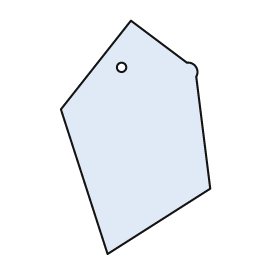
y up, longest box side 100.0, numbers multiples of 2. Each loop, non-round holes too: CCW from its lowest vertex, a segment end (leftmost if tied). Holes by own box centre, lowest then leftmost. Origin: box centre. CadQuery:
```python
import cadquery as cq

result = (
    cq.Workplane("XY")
    .moveTo(-12.0, -50.0)
    .lineTo(32.0, -22.0)
    .lineTo(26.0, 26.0)
    .threePointArc((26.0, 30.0), (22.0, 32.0))
    .lineTo(-2.0, 50.0)
    .lineTo(-32.0, 12.0)
    .close()
    .moveTo(-6.0, 30.0)
    .circle(2.0)
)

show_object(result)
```